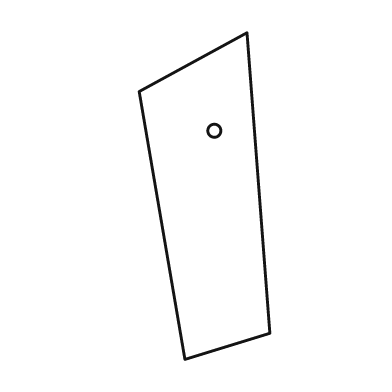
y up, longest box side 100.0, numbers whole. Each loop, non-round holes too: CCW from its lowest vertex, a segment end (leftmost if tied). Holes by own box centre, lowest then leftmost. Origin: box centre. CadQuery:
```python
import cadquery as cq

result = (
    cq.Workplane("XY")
    .moveTo(-6.0, -50.0)
    .lineTo(20.0, -42.0)
    .lineTo(13.0, 50.0)
    .lineTo(-20.0, 32.0)
    .close()
    .moveTo(3.0, 20.0)
    .circle(2.0)
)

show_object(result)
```